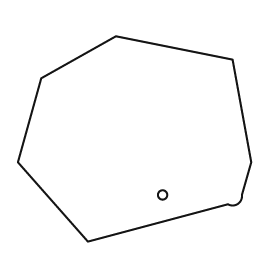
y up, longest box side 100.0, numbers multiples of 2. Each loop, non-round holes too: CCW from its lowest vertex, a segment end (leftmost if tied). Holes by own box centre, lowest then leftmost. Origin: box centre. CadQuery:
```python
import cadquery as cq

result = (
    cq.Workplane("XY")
    .moveTo(-20.0, -44.0)
    .lineTo(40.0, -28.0)
    .threePointArc((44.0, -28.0), (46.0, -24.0))
    .lineTo(50.0, -10.0)
    .lineTo(42.0, 34.0)
    .lineTo(-8.0, 44.0)
    .lineTo(-40.0, 26.0)
    .lineTo(-50.0, -10.0)
    .close()
    .moveTo(12.0, -24.0)
    .circle(2.0)
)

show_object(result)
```